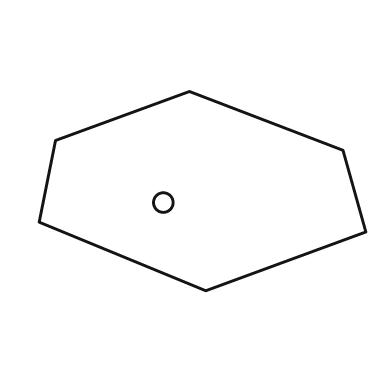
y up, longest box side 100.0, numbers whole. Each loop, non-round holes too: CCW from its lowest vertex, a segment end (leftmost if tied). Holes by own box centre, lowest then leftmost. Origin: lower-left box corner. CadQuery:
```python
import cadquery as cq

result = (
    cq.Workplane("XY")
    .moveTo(51.0, 0.0)
    .lineTo(100.0, 18.0)
    .lineTo(93.0, 43.0)
    .lineTo(46.0, 61.0)
    .lineTo(5.0, 46.0)
    .lineTo(0.0, 21.0)
    .close()
    .moveTo(38.0, 27.0)
    .circle(3.0)
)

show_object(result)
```